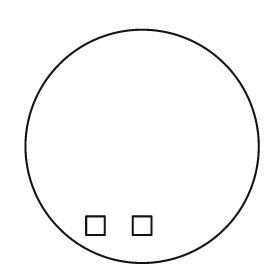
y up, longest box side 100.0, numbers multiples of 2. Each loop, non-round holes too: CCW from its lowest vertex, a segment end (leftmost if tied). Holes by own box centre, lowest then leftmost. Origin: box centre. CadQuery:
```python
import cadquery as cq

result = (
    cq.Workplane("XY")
    .moveTo(0.0, 0.0)
    .circle(50.0)
    .moveTo(-24.0, -38.0)
    .lineTo(-16.0, -38.0)
    .lineTo(-16.0, -30.0)
    .lineTo(-24.0, -30.0)
    .close()
    .moveTo(-4.0, -38.0)
    .lineTo(4.0, -38.0)
    .lineTo(4.0, -30.0)
    .lineTo(-4.0, -30.0)
    .close()
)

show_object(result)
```